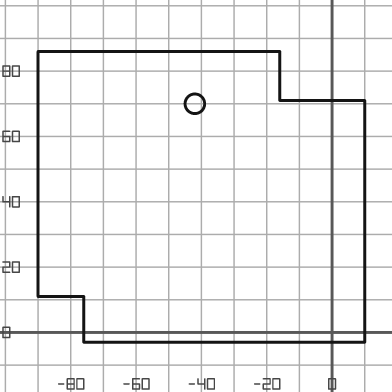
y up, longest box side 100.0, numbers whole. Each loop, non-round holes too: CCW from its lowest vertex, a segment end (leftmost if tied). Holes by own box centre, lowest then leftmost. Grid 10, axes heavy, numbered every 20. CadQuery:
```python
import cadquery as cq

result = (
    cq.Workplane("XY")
    .moveTo(-76.0, -3.0)
    .lineTo(10.0, -3.0)
    .lineTo(10.0, 71.0)
    .lineTo(-16.0, 71.0)
    .lineTo(-16.0, 86.0)
    .lineTo(-90.0, 86.0)
    .lineTo(-90.0, 11.0)
    .lineTo(-76.0, 11.0)
    .close()
    .moveTo(-42.0, 70.0)
    .circle(3.0)
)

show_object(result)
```